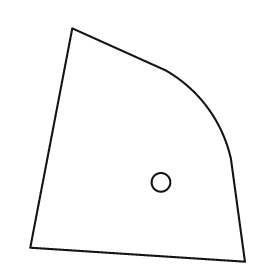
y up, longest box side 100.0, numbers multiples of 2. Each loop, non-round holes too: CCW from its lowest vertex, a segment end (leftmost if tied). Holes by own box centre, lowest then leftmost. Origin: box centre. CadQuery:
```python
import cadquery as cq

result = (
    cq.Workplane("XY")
    .moveTo(46.0, -50.0)
    .lineTo(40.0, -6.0)
    .threePointArc((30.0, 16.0), (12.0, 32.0))
    .lineTo(-28.0, 50.0)
    .lineTo(-46.0, -44.0)
    .close()
    .moveTo(10.0, -16.0)
    .circle(4.0)
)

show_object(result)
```